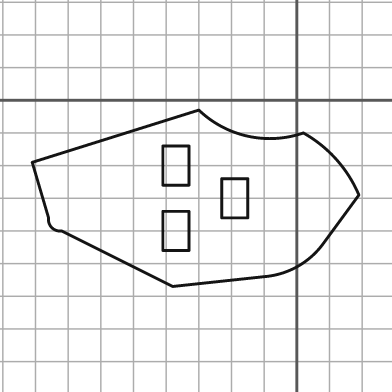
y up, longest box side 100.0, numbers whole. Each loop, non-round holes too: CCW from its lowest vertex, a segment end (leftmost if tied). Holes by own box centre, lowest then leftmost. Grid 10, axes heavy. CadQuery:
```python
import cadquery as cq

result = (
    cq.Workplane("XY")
    .moveTo(-38.0, -57.0)
    .lineTo(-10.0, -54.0)
    .threePointArc((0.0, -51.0), (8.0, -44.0))
    .lineTo(19.0, -29.0)
    .threePointArc((12.0, -18.0), (2.0, -10.0))
    .threePointArc((-15.0, -11.0), (-30.0, -3.0))
    .lineTo(-81.0, -19.0)
    .lineTo(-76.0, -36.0)
    .threePointArc((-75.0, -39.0), (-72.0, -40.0))
    .close()
    .moveTo(-41.0, -46.0)
    .lineTo(-33.0, -46.0)
    .lineTo(-33.0, -34.0)
    .lineTo(-41.0, -34.0)
    .close()
    .moveTo(-23.0, -36.0)
    .lineTo(-15.0, -36.0)
    .lineTo(-15.0, -24.0)
    .lineTo(-23.0, -24.0)
    .close()
    .moveTo(-41.0, -26.0)
    .lineTo(-33.0, -26.0)
    .lineTo(-33.0, -14.0)
    .lineTo(-41.0, -14.0)
    .close()
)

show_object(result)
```